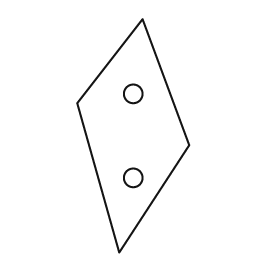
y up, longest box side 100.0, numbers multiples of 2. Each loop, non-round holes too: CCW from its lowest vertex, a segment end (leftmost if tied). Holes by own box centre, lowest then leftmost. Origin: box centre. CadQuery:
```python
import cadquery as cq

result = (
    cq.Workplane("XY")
    .moveTo(-6.0, -50.0)
    .lineTo(24.0, -4.0)
    .lineTo(4.0, 50.0)
    .lineTo(-24.0, 14.0)
    .close()
    .moveTo(0.0, -18.0)
    .circle(4.0)
    .moveTo(0.0, 18.0)
    .circle(4.0)
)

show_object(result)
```